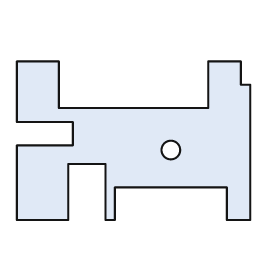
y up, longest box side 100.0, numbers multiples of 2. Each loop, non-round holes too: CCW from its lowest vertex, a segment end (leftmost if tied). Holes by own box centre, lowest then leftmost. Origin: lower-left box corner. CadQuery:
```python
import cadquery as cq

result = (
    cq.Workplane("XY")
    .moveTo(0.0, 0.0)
    .lineTo(22.0, 0.0)
    .lineTo(22.0, 24.0)
    .lineTo(38.0, 24.0)
    .lineTo(38.0, 0.0)
    .lineTo(42.0, 0.0)
    .lineTo(42.0, 14.0)
    .lineTo(90.0, 14.0)
    .lineTo(90.0, 0.0)
    .lineTo(100.0, 0.0)
    .lineTo(100.0, 58.0)
    .lineTo(96.0, 58.0)
    .lineTo(96.0, 68.0)
    .lineTo(82.0, 68.0)
    .lineTo(82.0, 48.0)
    .lineTo(18.0, 48.0)
    .lineTo(18.0, 68.0)
    .lineTo(0.0, 68.0)
    .lineTo(0.0, 42.0)
    .lineTo(24.0, 42.0)
    .lineTo(24.0, 32.0)
    .lineTo(0.0, 32.0)
    .close()
    .moveTo(66.0, 30.0)
    .circle(4.0)
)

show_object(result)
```